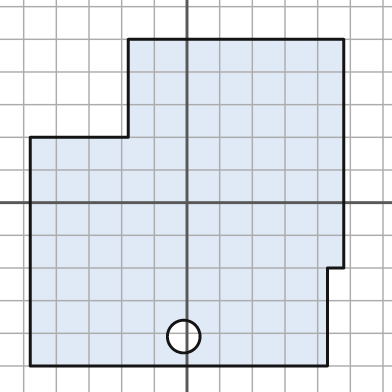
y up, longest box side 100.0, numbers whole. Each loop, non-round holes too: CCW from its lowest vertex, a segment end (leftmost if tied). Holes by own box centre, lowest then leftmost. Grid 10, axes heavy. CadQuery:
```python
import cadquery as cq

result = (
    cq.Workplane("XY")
    .moveTo(-48.0, -50.0)
    .lineTo(43.0, -50.0)
    .lineTo(43.0, -20.0)
    .lineTo(48.0, -20.0)
    .lineTo(48.0, 50.0)
    .lineTo(-18.0, 50.0)
    .lineTo(-18.0, 20.0)
    .lineTo(-48.0, 20.0)
    .close()
    .moveTo(-1.0, -41.0)
    .circle(5.0)
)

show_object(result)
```